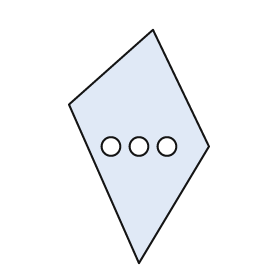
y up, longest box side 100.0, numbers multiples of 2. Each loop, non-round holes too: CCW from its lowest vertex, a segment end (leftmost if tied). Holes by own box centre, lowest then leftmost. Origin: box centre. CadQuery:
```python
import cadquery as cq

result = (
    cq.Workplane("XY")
    .moveTo(0.0, -50.0)
    .lineTo(30.0, 0.0)
    .lineTo(6.0, 50.0)
    .lineTo(-30.0, 18.0)
    .close()
    .moveTo(-12.0, 0.0)
    .circle(4.0)
    .moveTo(0.0, 0.0)
    .circle(4.0)
    .moveTo(12.0, 0.0)
    .circle(4.0)
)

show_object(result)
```